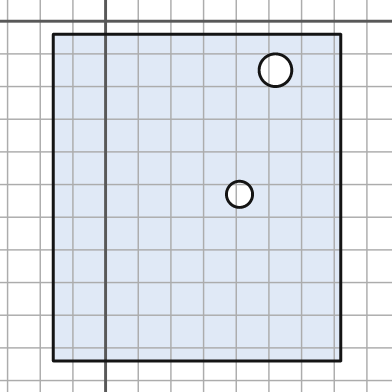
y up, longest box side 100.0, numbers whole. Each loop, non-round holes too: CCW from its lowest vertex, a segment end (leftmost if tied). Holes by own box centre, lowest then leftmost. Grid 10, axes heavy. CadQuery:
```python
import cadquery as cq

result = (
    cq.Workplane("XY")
    .moveTo(-16.0, -104.0)
    .lineTo(72.0, -104.0)
    .lineTo(72.0, -4.0)
    .lineTo(-16.0, -4.0)
    .close()
    .moveTo(41.0, -53.0)
    .circle(4.0)
    .moveTo(52.0, -15.0)
    .circle(5.0)
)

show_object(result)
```